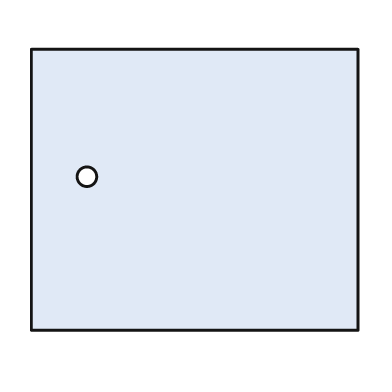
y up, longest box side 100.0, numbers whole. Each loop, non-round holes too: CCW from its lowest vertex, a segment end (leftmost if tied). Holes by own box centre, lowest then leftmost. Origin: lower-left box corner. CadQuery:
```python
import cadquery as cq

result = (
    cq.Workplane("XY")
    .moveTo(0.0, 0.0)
    .lineTo(100.0, 0.0)
    .lineTo(100.0, 86.0)
    .lineTo(0.0, 86.0)
    .close()
    .moveTo(17.0, 47.0)
    .circle(3.0)
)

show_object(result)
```